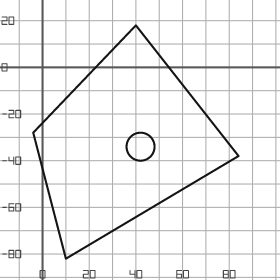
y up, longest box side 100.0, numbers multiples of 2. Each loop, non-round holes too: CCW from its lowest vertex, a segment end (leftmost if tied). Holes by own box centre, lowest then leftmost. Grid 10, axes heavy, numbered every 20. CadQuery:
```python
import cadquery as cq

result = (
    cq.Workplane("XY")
    .moveTo(10.0, -82.0)
    .lineTo(84.0, -38.0)
    .lineTo(40.0, 18.0)
    .lineTo(-4.0, -28.0)
    .close()
    .moveTo(42.0, -34.0)
    .circle(6.0)
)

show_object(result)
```